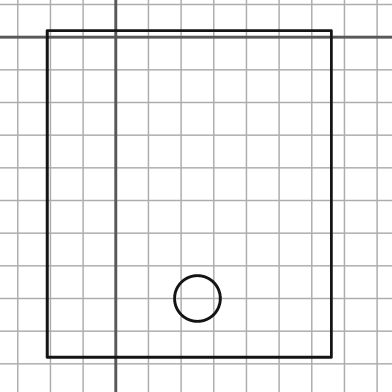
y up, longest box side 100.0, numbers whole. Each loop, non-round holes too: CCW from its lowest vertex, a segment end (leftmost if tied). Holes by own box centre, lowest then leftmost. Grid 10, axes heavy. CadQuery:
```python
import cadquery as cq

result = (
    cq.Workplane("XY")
    .moveTo(-21.0, -98.0)
    .lineTo(66.0, -98.0)
    .lineTo(66.0, 2.0)
    .lineTo(-21.0, 2.0)
    .close()
    .moveTo(25.0, -80.0)
    .circle(7.0)
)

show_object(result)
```